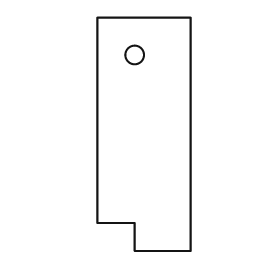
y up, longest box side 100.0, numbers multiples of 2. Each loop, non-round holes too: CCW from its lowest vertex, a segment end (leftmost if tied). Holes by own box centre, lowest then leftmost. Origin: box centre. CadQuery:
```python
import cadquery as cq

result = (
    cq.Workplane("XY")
    .moveTo(-4.0, -50.0)
    .lineTo(20.0, -50.0)
    .lineTo(20.0, 50.0)
    .lineTo(-20.0, 50.0)
    .lineTo(-20.0, -38.0)
    .lineTo(-4.0, -38.0)
    .close()
    .moveTo(-4.0, 34.0)
    .circle(4.0)
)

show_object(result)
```